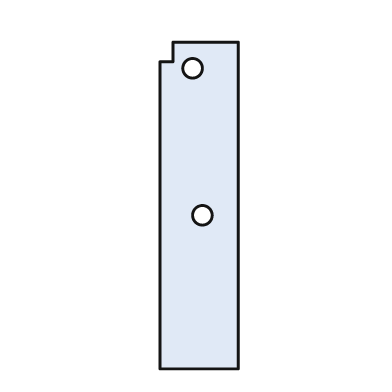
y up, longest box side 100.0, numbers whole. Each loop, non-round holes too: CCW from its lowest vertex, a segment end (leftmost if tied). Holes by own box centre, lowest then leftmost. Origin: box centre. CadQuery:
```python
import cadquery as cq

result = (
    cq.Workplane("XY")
    .moveTo(-12.0, -50.0)
    .lineTo(12.0, -50.0)
    .lineTo(12.0, 50.0)
    .lineTo(-8.0, 50.0)
    .lineTo(-8.0, 44.0)
    .lineTo(-12.0, 44.0)
    .close()
    .moveTo(1.0, -3.0)
    .circle(3.0)
    .moveTo(-2.0, 42.0)
    .circle(3.0)
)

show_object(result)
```